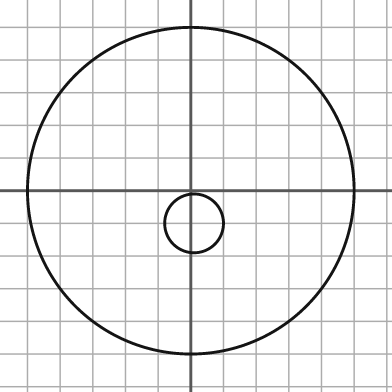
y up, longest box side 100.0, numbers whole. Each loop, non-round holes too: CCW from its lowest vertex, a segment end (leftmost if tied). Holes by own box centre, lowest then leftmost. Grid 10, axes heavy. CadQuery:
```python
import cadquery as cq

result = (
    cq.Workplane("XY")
    .moveTo(0.0, 0.0)
    .circle(50.0)
    .moveTo(1.0, -10.0)
    .circle(9.0)
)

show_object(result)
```